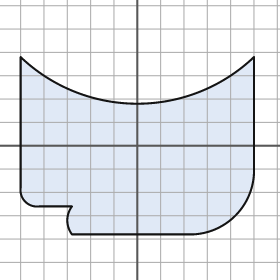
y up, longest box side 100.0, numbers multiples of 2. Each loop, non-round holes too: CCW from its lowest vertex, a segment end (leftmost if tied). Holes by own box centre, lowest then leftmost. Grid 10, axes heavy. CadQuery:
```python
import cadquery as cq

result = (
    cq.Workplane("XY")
    .moveTo(-28.0, -38.0)
    .lineTo(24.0, -38.0)
    .threePointArc((42.0, -30.0), (50.0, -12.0))
    .lineTo(50.0, 38.0)
    .threePointArc((0.0, 18.0), (-50.0, 38.0))
    .lineTo(-50.0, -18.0)
    .threePointArc((-48.0, -24.0), (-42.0, -26.0))
    .lineTo(-28.0, -26.0)
    .threePointArc((-30.0, -32.0), (-28.0, -38.0))
    .close()
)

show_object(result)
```